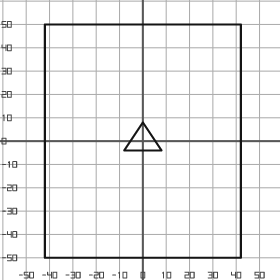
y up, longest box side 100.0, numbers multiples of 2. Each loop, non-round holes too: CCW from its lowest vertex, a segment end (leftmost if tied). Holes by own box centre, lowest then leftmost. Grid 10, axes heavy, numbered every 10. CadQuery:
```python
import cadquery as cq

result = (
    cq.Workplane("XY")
    .moveTo(-42.0, -50.0)
    .lineTo(42.0, -50.0)
    .lineTo(42.0, 50.0)
    .lineTo(-42.0, 50.0)
    .close()
    .moveTo(-8.0, -4.0)
    .lineTo(8.0, -4.0)
    .lineTo(0.0, 8.0)
    .close()
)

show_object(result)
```